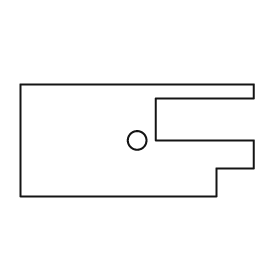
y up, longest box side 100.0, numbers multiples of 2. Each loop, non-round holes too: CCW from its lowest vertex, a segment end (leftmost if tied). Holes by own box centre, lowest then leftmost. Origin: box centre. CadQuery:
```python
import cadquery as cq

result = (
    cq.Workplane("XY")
    .moveTo(-50.0, -24.0)
    .lineTo(34.0, -24.0)
    .lineTo(34.0, -12.0)
    .lineTo(50.0, -12.0)
    .lineTo(50.0, 0.0)
    .lineTo(8.0, 0.0)
    .lineTo(8.0, 18.0)
    .lineTo(50.0, 18.0)
    .lineTo(50.0, 24.0)
    .lineTo(-50.0, 24.0)
    .close()
    .moveTo(0.0, 0.0)
    .circle(4.0)
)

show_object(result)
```